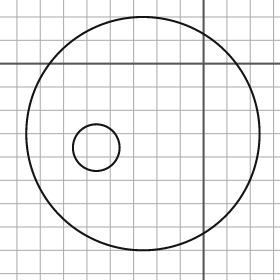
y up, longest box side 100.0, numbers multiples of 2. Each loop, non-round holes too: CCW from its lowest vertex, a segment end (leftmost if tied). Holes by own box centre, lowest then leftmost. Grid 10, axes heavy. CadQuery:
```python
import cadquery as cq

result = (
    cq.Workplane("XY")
    .moveTo(-26.0, -30.0)
    .circle(50.0)
    .moveTo(-46.0, -36.0)
    .circle(10.0)
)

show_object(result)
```